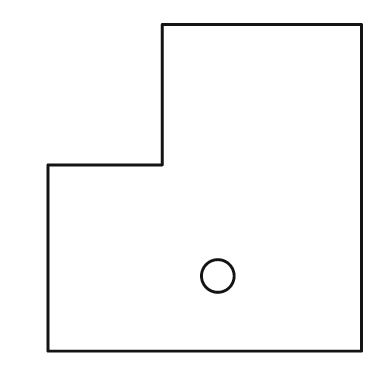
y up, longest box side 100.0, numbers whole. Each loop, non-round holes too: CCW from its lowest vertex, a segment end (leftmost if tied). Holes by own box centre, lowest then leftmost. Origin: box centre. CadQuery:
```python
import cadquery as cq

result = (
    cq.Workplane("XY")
    .moveTo(-48.0, -50.0)
    .lineTo(48.0, -50.0)
    .lineTo(48.0, 50.0)
    .lineTo(-13.0, 50.0)
    .lineTo(-13.0, 7.0)
    .lineTo(-48.0, 7.0)
    .close()
    .moveTo(4.0, -27.0)
    .circle(5.0)
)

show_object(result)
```